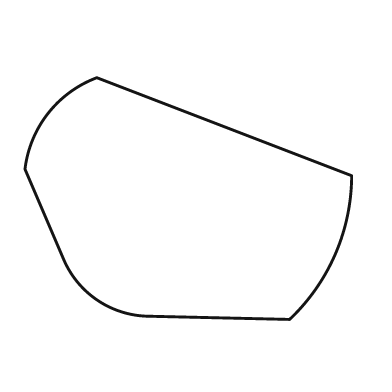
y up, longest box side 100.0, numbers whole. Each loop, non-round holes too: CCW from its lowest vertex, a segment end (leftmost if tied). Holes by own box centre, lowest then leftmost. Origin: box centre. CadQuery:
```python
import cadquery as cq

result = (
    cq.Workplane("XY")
    .moveTo(31.0, -37.0)
    .threePointArc((45.0, -17.0), (50.0, 7.0))
    .lineTo(-28.0, 37.0)
    .threePointArc((-43.0, 26.0), (-50.0, 9.0))
    .lineTo(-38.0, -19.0)
    .threePointArc((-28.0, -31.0), (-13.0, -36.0))
    .close()
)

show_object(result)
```